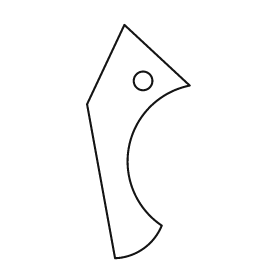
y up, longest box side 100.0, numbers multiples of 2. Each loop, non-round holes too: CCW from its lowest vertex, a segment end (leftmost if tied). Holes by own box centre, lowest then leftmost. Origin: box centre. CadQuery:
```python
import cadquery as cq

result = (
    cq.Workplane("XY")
    .moveTo(-10.0, -50.0)
    .threePointArc((2.0, -46.0), (10.0, -36.0))
    .threePointArc((-4.0, -2.0), (22.0, 24.0))
    .lineTo(-6.0, 50.0)
    .lineTo(-22.0, 16.0)
    .close()
    .moveTo(2.0, 26.0)
    .circle(4.0)
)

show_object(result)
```